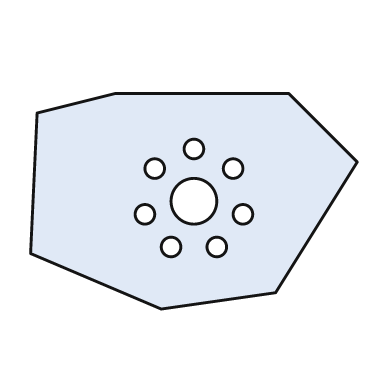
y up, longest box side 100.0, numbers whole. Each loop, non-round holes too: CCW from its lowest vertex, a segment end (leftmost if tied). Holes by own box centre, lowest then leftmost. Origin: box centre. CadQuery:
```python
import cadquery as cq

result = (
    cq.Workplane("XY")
    .moveTo(-10.0, -33.0)
    .lineTo(25.0, -28.0)
    .lineTo(50.0, 12.0)
    .lineTo(29.0, 33.0)
    .lineTo(-24.0, 33.0)
    .lineTo(-48.0, 27.0)
    .lineTo(-50.0, -16.0)
    .close()
    .moveTo(-7.0, -14.0)
    .circle(3.0)
    .moveTo(7.0, -14.0)
    .circle(3.0)
    .moveTo(-15.0, -4.0)
    .circle(3.0)
    .moveTo(15.0, -4.0)
    .circle(3.0)
    .moveTo(0.0, 0.0)
    .circle(7.0)
    .moveTo(-12.0, 10.0)
    .circle(3.0)
    .moveTo(12.0, 10.0)
    .circle(3.0)
    .moveTo(0.0, 16.0)
    .circle(3.0)
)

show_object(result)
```